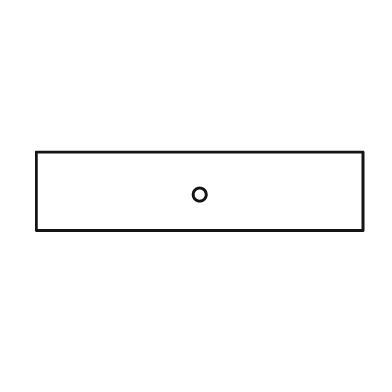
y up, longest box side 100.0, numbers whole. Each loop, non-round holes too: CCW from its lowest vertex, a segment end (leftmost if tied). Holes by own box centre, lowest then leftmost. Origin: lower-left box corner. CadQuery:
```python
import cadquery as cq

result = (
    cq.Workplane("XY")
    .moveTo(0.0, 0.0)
    .lineTo(100.0, 0.0)
    .lineTo(100.0, 24.0)
    .lineTo(0.0, 24.0)
    .close()
    .moveTo(50.0, 11.0)
    .circle(2.0)
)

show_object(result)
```